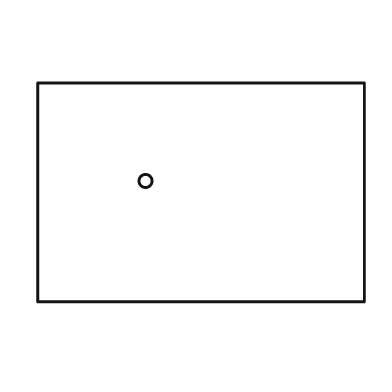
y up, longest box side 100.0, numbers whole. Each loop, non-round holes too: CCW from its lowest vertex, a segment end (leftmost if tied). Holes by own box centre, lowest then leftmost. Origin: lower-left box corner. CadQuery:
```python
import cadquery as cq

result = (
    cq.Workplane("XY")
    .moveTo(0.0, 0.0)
    .lineTo(100.0, 0.0)
    .lineTo(100.0, 67.0)
    .lineTo(0.0, 67.0)
    .close()
    .moveTo(33.0, 37.0)
    .circle(2.0)
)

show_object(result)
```